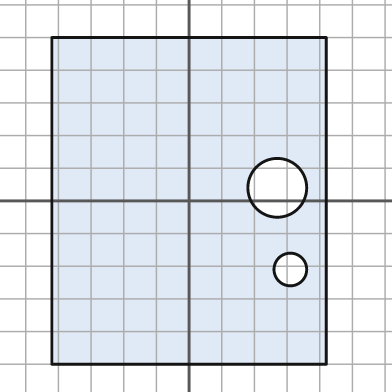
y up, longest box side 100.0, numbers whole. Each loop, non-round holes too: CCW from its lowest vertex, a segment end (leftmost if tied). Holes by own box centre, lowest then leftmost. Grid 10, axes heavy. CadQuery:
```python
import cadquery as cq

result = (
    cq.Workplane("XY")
    .moveTo(-42.0, -50.0)
    .lineTo(42.0, -50.0)
    .lineTo(42.0, 50.0)
    .lineTo(-42.0, 50.0)
    .close()
    .moveTo(31.0, -21.0)
    .circle(5.0)
    .moveTo(27.0, 4.0)
    .circle(9.0)
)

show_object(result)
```